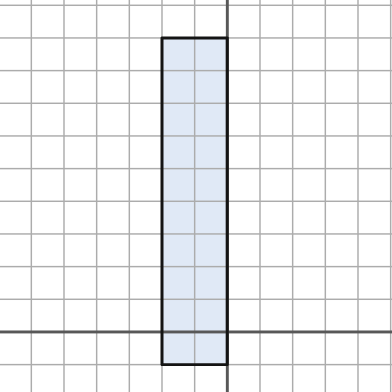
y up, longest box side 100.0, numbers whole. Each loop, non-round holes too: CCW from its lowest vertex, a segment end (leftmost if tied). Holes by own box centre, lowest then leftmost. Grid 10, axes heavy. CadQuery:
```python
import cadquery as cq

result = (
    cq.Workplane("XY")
    .moveTo(-20.0, -10.0)
    .lineTo(0.0, -10.0)
    .lineTo(0.0, 90.0)
    .lineTo(-20.0, 90.0)
    .close()
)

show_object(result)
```